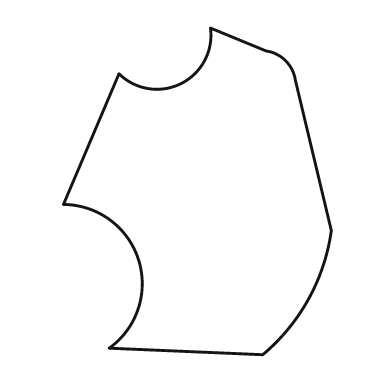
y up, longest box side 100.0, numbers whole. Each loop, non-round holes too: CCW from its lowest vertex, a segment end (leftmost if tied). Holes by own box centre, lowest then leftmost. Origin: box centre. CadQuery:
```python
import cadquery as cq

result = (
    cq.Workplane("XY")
    .moveTo(20.0, -50.0)
    .threePointArc((34.0, -33.0), (41.0, -12.0))
    .lineTo(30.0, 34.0)
    .threePointArc((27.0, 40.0), (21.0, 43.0))
    .lineTo(4.0, 50.0)
    .threePointArc((-5.0, 33.0), (-24.0, 36.0))
    .lineTo(-41.0, -4.0)
    .threePointArc((-18.0, -21.0), (-27.0, -48.0))
    .close()
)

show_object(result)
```